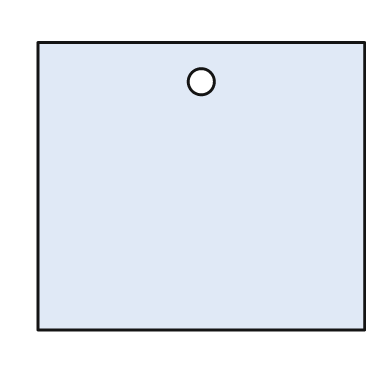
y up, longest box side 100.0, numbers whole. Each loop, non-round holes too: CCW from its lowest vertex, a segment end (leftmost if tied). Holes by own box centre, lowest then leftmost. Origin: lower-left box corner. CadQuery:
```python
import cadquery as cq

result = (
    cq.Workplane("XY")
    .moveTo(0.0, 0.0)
    .lineTo(100.0, 0.0)
    .lineTo(100.0, 88.0)
    .lineTo(0.0, 88.0)
    .close()
    .moveTo(50.0, 76.0)
    .circle(4.0)
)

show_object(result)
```